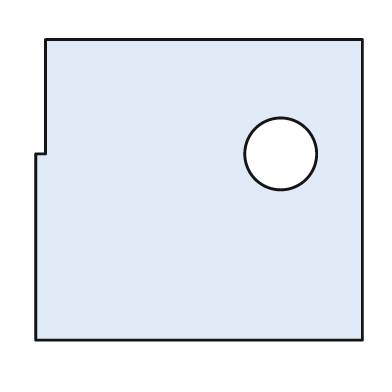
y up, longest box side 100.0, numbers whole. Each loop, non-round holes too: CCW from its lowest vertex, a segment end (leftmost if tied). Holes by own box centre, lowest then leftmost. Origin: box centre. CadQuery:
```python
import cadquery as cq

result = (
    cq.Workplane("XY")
    .moveTo(-50.0, -46.0)
    .lineTo(50.0, -46.0)
    .lineTo(50.0, 46.0)
    .lineTo(-47.0, 46.0)
    .lineTo(-47.0, 11.0)
    .lineTo(-50.0, 11.0)
    .close()
    .moveTo(25.0, 11.0)
    .circle(11.0)
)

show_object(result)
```